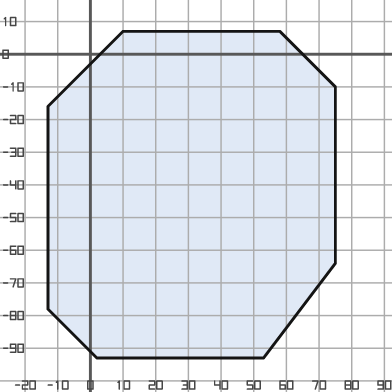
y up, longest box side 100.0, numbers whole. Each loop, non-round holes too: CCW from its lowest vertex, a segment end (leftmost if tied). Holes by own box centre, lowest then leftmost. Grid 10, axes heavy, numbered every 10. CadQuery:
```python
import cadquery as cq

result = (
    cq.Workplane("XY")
    .moveTo(2.0, -93.0)
    .lineTo(53.0, -93.0)
    .lineTo(75.0, -64.0)
    .lineTo(75.0, -10.0)
    .lineTo(58.0, 7.0)
    .lineTo(10.0, 7.0)
    .lineTo(-13.0, -16.0)
    .lineTo(-13.0, -78.0)
    .close()
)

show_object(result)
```